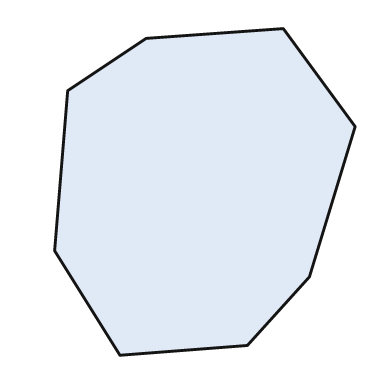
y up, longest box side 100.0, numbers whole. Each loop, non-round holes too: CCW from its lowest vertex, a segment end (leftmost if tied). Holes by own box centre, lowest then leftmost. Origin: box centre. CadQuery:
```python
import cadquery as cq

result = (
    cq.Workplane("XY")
    .moveTo(-26.0, -50.0)
    .lineTo(13.0, -47.0)
    .lineTo(32.0, -26.0)
    .lineTo(46.0, 20.0)
    .lineTo(24.0, 50.0)
    .lineTo(-18.0, 47.0)
    .lineTo(-42.0, 31.0)
    .lineTo(-46.0, -18.0)
    .close()
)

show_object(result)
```